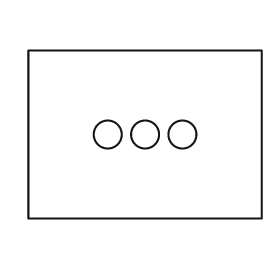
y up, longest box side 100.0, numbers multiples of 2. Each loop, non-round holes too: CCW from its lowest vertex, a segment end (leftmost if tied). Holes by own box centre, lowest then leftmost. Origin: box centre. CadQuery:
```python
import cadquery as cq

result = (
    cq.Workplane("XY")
    .moveTo(-50.0, -36.0)
    .lineTo(50.0, -36.0)
    .lineTo(50.0, 36.0)
    .lineTo(-50.0, 36.0)
    .close()
    .moveTo(-16.0, 0.0)
    .circle(6.0)
    .moveTo(0.0, 0.0)
    .circle(6.0)
    .moveTo(16.0, 0.0)
    .circle(6.0)
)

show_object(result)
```